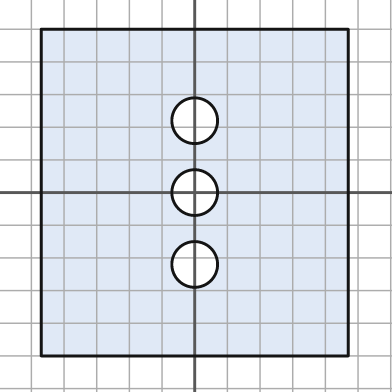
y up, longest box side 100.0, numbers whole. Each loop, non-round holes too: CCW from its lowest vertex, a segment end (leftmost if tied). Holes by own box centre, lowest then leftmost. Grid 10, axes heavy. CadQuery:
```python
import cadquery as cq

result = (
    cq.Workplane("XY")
    .moveTo(-47.0, -50.0)
    .lineTo(47.0, -50.0)
    .lineTo(47.0, 50.0)
    .lineTo(-47.0, 50.0)
    .close()
    .moveTo(0.0, -22.0)
    .circle(7.0)
    .moveTo(0.0, 0.0)
    .circle(7.0)
    .moveTo(0.0, 22.0)
    .circle(7.0)
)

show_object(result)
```